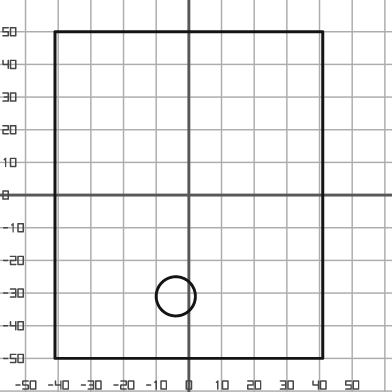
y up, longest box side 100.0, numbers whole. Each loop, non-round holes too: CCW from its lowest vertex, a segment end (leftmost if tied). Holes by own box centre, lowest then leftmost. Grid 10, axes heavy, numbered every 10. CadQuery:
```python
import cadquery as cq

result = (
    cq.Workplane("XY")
    .moveTo(-41.0, -50.0)
    .lineTo(41.0, -50.0)
    .lineTo(41.0, 50.0)
    .lineTo(-41.0, 50.0)
    .close()
    .moveTo(-4.0, -31.0)
    .circle(6.0)
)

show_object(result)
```